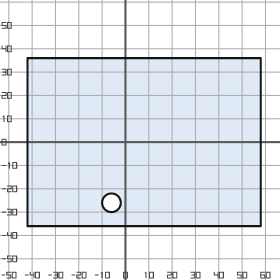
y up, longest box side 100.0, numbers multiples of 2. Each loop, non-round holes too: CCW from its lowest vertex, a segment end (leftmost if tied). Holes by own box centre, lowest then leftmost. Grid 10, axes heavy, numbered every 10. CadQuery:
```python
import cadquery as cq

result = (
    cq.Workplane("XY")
    .moveTo(-42.0, -36.0)
    .lineTo(58.0, -36.0)
    .lineTo(58.0, 36.0)
    .lineTo(-42.0, 36.0)
    .close()
    .moveTo(-6.0, -26.0)
    .circle(4.0)
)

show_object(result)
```